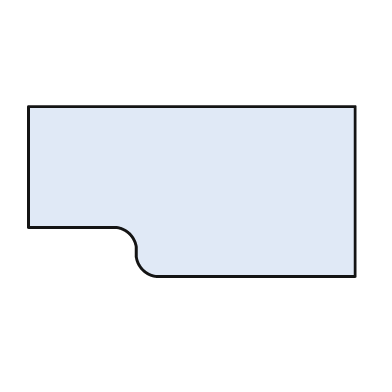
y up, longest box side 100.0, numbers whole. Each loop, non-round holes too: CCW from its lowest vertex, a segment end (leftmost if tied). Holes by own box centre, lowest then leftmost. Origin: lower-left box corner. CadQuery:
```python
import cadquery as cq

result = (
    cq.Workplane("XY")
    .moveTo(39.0, 0.0)
    .lineTo(100.0, 0.0)
    .lineTo(100.0, 52.0)
    .lineTo(0.0, 52.0)
    .lineTo(0.0, 15.0)
    .lineTo(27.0, 15.0)
    .threePointArc((31.0, 13.0), (33.0, 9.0))
    .lineTo(33.0, 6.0)
    .threePointArc((35.0, 2.0), (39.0, 0.0))
    .close()
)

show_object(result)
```